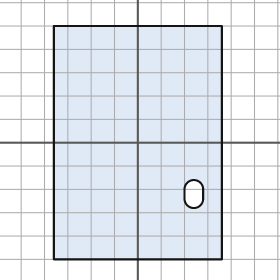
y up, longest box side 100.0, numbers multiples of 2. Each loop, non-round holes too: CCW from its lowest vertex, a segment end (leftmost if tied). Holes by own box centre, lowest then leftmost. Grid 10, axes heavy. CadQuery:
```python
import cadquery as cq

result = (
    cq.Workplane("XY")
    .moveTo(-36.0, -50.0)
    .lineTo(36.0, -50.0)
    .lineTo(36.0, 50.0)
    .lineTo(-36.0, 50.0)
    .close()
    .moveTo(20.0, -24.0)
    .threePointArc((24.0, -28.0), (28.0, -24.0))
    .lineTo(28.0, -20.0)
    .threePointArc((24.0, -16.0), (20.0, -20.0))
    .close()
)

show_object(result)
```